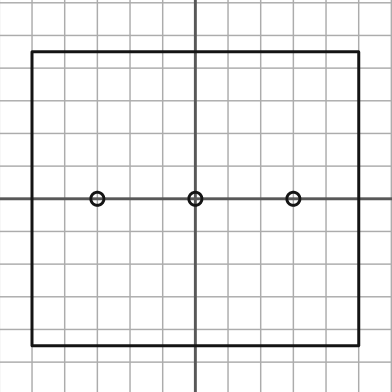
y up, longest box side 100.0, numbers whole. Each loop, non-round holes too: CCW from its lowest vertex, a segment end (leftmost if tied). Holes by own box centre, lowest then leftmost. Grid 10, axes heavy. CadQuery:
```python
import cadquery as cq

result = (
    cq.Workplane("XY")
    .moveTo(-50.0, -45.0)
    .lineTo(50.0, -45.0)
    .lineTo(50.0, 45.0)
    .lineTo(-50.0, 45.0)
    .close()
    .moveTo(-30.0, 0.0)
    .circle(2.0)
    .moveTo(0.0, 0.0)
    .circle(2.0)
    .moveTo(30.0, 0.0)
    .circle(2.0)
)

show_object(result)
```